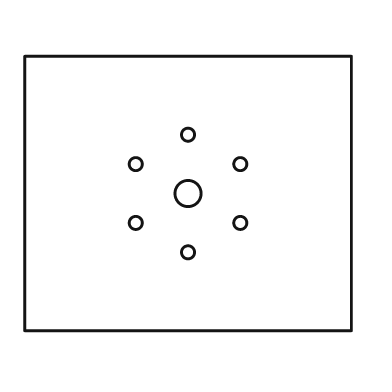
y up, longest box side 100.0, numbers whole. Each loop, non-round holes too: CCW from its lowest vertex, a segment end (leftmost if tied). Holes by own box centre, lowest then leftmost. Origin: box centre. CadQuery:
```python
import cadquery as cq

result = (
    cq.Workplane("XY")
    .moveTo(-50.0, -42.0)
    .lineTo(50.0, -42.0)
    .lineTo(50.0, 42.0)
    .lineTo(-50.0, 42.0)
    .close()
    .moveTo(0.0, -18.0)
    .circle(2.0)
    .moveTo(-16.0, -9.0)
    .circle(2.0)
    .moveTo(16.0, -9.0)
    .circle(2.0)
    .moveTo(0.0, 0.0)
    .circle(4.0)
    .moveTo(-16.0, 9.0)
    .circle(2.0)
    .moveTo(16.0, 9.0)
    .circle(2.0)
    .moveTo(0.0, 18.0)
    .circle(2.0)
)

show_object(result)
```